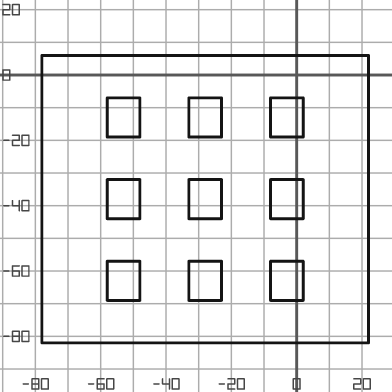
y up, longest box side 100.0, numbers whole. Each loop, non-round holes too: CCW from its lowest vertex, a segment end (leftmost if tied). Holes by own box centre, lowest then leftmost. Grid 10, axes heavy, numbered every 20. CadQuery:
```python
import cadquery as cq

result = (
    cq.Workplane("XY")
    .moveTo(-78.0, -82.0)
    .lineTo(22.0, -82.0)
    .lineTo(22.0, 6.0)
    .lineTo(-78.0, 6.0)
    .close()
    .moveTo(-58.0, -69.0)
    .lineTo(-48.0, -69.0)
    .lineTo(-48.0, -57.0)
    .lineTo(-58.0, -57.0)
    .close()
    .moveTo(-33.0, -69.0)
    .lineTo(-23.0, -69.0)
    .lineTo(-23.0, -57.0)
    .lineTo(-33.0, -57.0)
    .close()
    .moveTo(-8.0, -69.0)
    .lineTo(2.0, -69.0)
    .lineTo(2.0, -57.0)
    .lineTo(-8.0, -57.0)
    .close()
    .moveTo(-58.0, -44.0)
    .lineTo(-48.0, -44.0)
    .lineTo(-48.0, -32.0)
    .lineTo(-58.0, -32.0)
    .close()
    .moveTo(-33.0, -44.0)
    .lineTo(-23.0, -44.0)
    .lineTo(-23.0, -32.0)
    .lineTo(-33.0, -32.0)
    .close()
    .moveTo(-8.0, -44.0)
    .lineTo(2.0, -44.0)
    .lineTo(2.0, -32.0)
    .lineTo(-8.0, -32.0)
    .close()
    .moveTo(-58.0, -19.0)
    .lineTo(-48.0, -19.0)
    .lineTo(-48.0, -7.0)
    .lineTo(-58.0, -7.0)
    .close()
    .moveTo(-33.0, -19.0)
    .lineTo(-23.0, -19.0)
    .lineTo(-23.0, -7.0)
    .lineTo(-33.0, -7.0)
    .close()
    .moveTo(-8.0, -19.0)
    .lineTo(2.0, -19.0)
    .lineTo(2.0, -7.0)
    .lineTo(-8.0, -7.0)
    .close()
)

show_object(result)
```